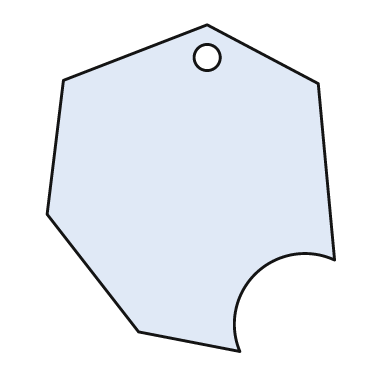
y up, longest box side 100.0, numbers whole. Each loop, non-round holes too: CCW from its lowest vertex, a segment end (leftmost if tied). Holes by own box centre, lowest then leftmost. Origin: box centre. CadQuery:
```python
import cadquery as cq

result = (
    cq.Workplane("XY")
    .moveTo(15.0, -50.0)
    .threePointArc((20.0, -26.0), (44.0, -22.0))
    .lineTo(39.0, 32.0)
    .lineTo(5.0, 50.0)
    .lineTo(-39.0, 33.0)
    .lineTo(-44.0, -8.0)
    .lineTo(-16.0, -44.0)
    .close()
    .moveTo(5.0, 40.0)
    .circle(4.0)
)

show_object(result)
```